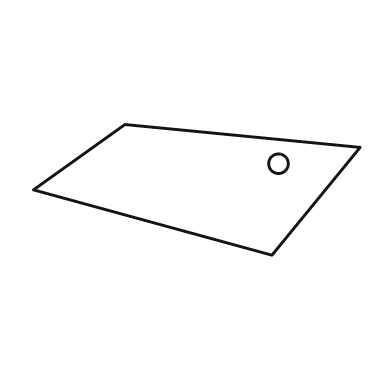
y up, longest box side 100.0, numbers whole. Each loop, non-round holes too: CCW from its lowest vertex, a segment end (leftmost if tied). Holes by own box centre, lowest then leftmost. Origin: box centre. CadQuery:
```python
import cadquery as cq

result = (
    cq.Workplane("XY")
    .moveTo(23.0, -20.0)
    .lineTo(50.0, 13.0)
    .lineTo(-22.0, 20.0)
    .lineTo(-50.0, 0.0)
    .close()
    .moveTo(25.0, 8.0)
    .circle(3.0)
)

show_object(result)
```